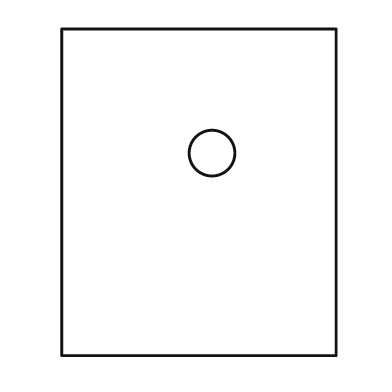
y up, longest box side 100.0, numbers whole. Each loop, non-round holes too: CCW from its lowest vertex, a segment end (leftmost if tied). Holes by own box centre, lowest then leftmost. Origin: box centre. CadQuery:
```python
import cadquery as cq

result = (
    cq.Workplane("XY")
    .moveTo(-42.0, -50.0)
    .lineTo(42.0, -50.0)
    .lineTo(42.0, 50.0)
    .lineTo(-42.0, 50.0)
    .close()
    .moveTo(4.0, 12.0)
    .circle(7.0)
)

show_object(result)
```